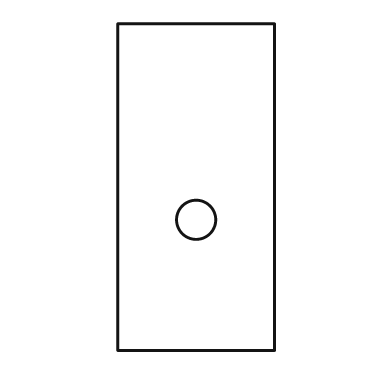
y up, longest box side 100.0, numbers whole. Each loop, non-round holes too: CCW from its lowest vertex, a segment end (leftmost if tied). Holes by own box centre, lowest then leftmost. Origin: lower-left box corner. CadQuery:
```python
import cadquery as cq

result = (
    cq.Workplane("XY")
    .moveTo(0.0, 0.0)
    .lineTo(48.0, 0.0)
    .lineTo(48.0, 100.0)
    .lineTo(0.0, 100.0)
    .close()
    .moveTo(24.0, 40.0)
    .circle(6.0)
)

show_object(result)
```